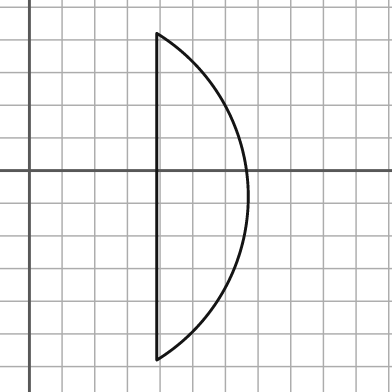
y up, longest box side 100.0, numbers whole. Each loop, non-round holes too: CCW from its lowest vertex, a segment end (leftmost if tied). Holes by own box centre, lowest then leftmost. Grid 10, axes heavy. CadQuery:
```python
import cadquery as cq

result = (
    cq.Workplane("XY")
    .moveTo(39.0, -58.0)
    .threePointArc((67.0, -8.0), (39.0, 42.0))
    .close()
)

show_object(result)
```